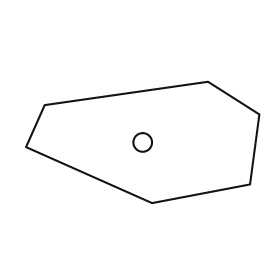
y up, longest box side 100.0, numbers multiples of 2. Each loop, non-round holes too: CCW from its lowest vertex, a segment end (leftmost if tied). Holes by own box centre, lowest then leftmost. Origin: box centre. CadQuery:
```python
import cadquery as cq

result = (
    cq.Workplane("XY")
    .moveTo(4.0, -26.0)
    .lineTo(46.0, -18.0)
    .lineTo(50.0, 12.0)
    .lineTo(28.0, 26.0)
    .lineTo(-42.0, 16.0)
    .lineTo(-50.0, -2.0)
    .close()
    .moveTo(0.0, 0.0)
    .circle(4.0)
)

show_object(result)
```